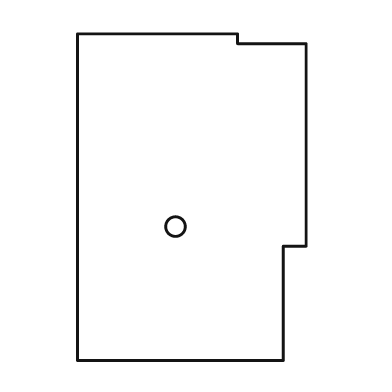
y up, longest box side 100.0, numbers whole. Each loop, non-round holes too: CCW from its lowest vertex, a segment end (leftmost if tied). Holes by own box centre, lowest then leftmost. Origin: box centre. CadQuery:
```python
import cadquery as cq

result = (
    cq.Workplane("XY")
    .moveTo(-35.0, -50.0)
    .lineTo(28.0, -50.0)
    .lineTo(28.0, -15.0)
    .lineTo(35.0, -15.0)
    .lineTo(35.0, 47.0)
    .lineTo(14.0, 47.0)
    .lineTo(14.0, 50.0)
    .lineTo(-35.0, 50.0)
    .close()
    .moveTo(-5.0, -9.0)
    .circle(3.0)
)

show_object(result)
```